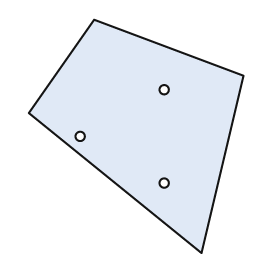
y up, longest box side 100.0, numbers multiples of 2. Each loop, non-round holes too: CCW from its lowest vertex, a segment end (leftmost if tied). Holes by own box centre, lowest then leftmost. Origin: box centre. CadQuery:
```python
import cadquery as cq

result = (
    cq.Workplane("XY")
    .moveTo(28.0, -50.0)
    .lineTo(46.0, 26.0)
    .lineTo(-18.0, 50.0)
    .lineTo(-46.0, 10.0)
    .close()
    .moveTo(12.0, -20.0)
    .circle(2.0)
    .moveTo(-24.0, 0.0)
    .circle(2.0)
    .moveTo(12.0, 20.0)
    .circle(2.0)
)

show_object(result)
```